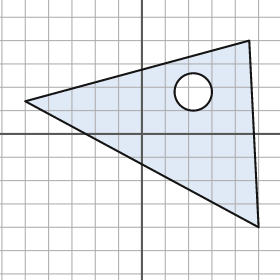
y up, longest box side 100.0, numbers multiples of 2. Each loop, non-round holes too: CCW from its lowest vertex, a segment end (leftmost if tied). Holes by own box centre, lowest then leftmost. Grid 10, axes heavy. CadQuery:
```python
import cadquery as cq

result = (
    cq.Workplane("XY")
    .moveTo(50.0, -40.0)
    .lineTo(46.0, 40.0)
    .lineTo(-50.0, 14.0)
    .close()
    .moveTo(22.0, 18.0)
    .circle(8.0)
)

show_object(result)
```